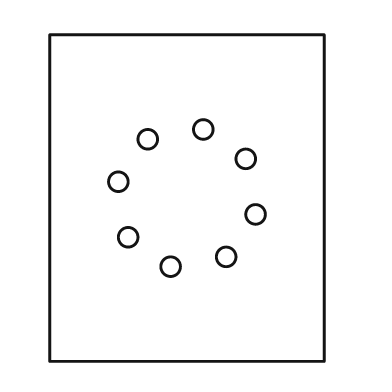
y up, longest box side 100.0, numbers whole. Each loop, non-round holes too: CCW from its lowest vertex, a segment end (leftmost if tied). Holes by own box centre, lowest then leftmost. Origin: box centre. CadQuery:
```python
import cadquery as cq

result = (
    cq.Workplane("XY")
    .moveTo(-42.0, -50.0)
    .lineTo(42.0, -50.0)
    .lineTo(42.0, 50.0)
    .lineTo(-42.0, 50.0)
    .close()
    .moveTo(-5.0, -21.0)
    .circle(3.0)
    .moveTo(12.0, -18.0)
    .circle(3.0)
    .moveTo(-18.0, -12.0)
    .circle(3.0)
    .moveTo(21.0, -5.0)
    .circle(3.0)
    .moveTo(-21.0, 5.0)
    .circle(3.0)
    .moveTo(18.0, 12.0)
    .circle(3.0)
    .moveTo(-12.0, 18.0)
    .circle(3.0)
    .moveTo(5.0, 21.0)
    .circle(3.0)
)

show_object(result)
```